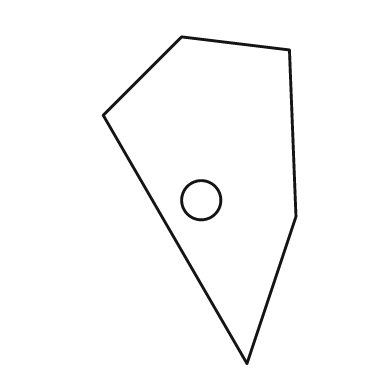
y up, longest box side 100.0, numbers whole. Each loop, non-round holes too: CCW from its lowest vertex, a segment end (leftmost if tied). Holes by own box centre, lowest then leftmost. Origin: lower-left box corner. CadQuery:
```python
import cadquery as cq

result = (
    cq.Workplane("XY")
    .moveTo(44.0, 0.0)
    .lineTo(59.0, 45.0)
    .lineTo(57.0, 96.0)
    .lineTo(24.0, 100.0)
    .lineTo(0.0, 76.0)
    .close()
    .moveTo(30.0, 50.0)
    .circle(6.0)
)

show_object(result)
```